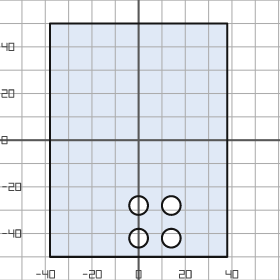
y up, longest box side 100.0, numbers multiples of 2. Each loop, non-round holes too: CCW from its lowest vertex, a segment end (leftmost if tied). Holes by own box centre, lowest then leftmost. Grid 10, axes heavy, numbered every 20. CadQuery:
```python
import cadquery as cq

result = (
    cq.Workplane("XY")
    .moveTo(-38.0, -50.0)
    .lineTo(38.0, -50.0)
    .lineTo(38.0, 50.0)
    .lineTo(-38.0, 50.0)
    .close()
    .moveTo(0.0, -42.0)
    .circle(4.0)
    .moveTo(14.0, -42.0)
    .circle(4.0)
    .moveTo(0.0, -28.0)
    .circle(4.0)
    .moveTo(14.0, -28.0)
    .circle(4.0)
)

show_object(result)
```